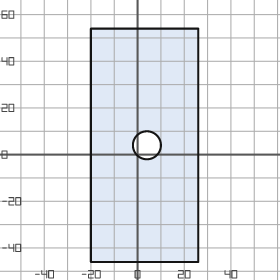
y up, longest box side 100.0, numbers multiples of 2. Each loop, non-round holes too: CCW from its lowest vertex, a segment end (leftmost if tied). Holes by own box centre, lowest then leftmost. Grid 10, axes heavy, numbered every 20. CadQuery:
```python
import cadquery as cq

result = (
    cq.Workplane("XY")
    .moveTo(-20.0, -46.0)
    .lineTo(26.0, -46.0)
    .lineTo(26.0, 54.0)
    .lineTo(-20.0, 54.0)
    .close()
    .moveTo(4.0, 4.0)
    .circle(6.0)
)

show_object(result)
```